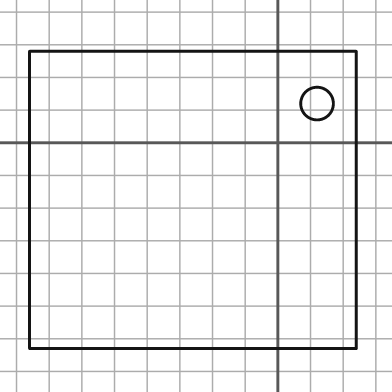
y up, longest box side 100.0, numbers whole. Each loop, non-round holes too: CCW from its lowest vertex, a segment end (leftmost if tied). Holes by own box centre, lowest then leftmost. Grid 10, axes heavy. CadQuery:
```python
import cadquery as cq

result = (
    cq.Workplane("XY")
    .moveTo(-76.0, -63.0)
    .lineTo(24.0, -63.0)
    .lineTo(24.0, 28.0)
    .lineTo(-76.0, 28.0)
    .close()
    .moveTo(12.0, 12.0)
    .circle(5.0)
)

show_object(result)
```